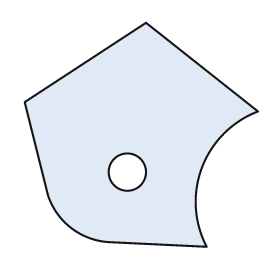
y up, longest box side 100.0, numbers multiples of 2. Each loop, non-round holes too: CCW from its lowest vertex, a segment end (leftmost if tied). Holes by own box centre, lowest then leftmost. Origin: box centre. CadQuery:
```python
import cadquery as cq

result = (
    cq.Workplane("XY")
    .moveTo(28.0, -48.0)
    .threePointArc((26.0, -14.0), (50.0, 10.0))
    .lineTo(2.0, 48.0)
    .lineTo(-50.0, 14.0)
    .lineTo(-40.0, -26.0)
    .threePointArc((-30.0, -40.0), (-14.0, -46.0))
    .close()
    .moveTo(-6.0, -16.0)
    .circle(8.0)
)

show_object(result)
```